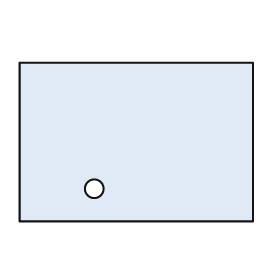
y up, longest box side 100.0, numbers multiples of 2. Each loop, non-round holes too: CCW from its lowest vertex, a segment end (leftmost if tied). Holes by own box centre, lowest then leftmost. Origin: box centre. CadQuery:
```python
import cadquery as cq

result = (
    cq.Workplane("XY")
    .moveTo(-50.0, -34.0)
    .lineTo(50.0, -34.0)
    .lineTo(50.0, 34.0)
    .lineTo(-50.0, 34.0)
    .close()
    .moveTo(-18.0, -20.0)
    .circle(4.0)
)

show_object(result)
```